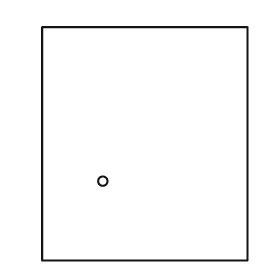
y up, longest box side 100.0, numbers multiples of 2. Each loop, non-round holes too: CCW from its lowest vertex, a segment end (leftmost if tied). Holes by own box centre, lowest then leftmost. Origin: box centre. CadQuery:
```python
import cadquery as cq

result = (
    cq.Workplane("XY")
    .moveTo(-44.0, -50.0)
    .lineTo(44.0, -50.0)
    .lineTo(44.0, 50.0)
    .lineTo(-44.0, 50.0)
    .close()
    .moveTo(-18.0, -16.0)
    .circle(2.0)
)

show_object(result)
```